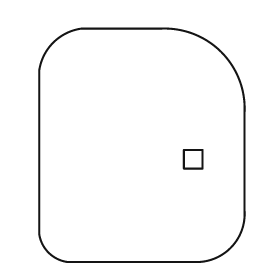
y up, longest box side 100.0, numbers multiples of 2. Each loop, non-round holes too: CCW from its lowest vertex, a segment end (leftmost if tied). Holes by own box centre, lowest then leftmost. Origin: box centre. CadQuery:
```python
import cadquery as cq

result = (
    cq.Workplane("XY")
    .moveTo(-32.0, -50.0)
    .lineTo(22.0, -50.0)
    .threePointArc((38.0, -44.0), (44.0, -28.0))
    .lineTo(44.0, 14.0)
    .threePointArc((34.0, 40.0), (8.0, 50.0))
    .lineTo(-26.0, 50.0)
    .threePointArc((-38.0, 44.0), (-44.0, 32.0))
    .lineTo(-44.0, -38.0)
    .threePointArc((-40.0, -46.0), (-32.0, -50.0))
    .close()
    .moveTo(18.0, -10.0)
    .lineTo(26.0, -10.0)
    .lineTo(26.0, -2.0)
    .lineTo(18.0, -2.0)
    .close()
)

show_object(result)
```